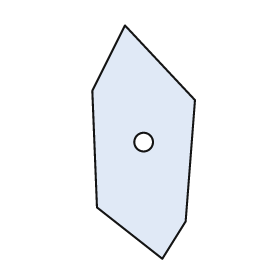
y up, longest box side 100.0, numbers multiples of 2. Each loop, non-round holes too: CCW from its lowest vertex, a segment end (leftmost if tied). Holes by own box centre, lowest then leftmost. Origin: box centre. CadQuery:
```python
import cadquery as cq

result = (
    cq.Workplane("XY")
    .moveTo(8.0, -50.0)
    .lineTo(18.0, -34.0)
    .lineTo(22.0, 18.0)
    .lineTo(-8.0, 50.0)
    .lineTo(-22.0, 22.0)
    .lineTo(-20.0, -28.0)
    .close()
    .moveTo(0.0, 0.0)
    .circle(4.0)
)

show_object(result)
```